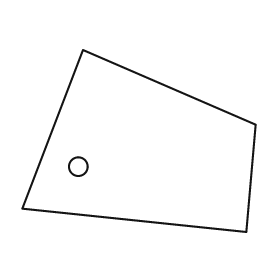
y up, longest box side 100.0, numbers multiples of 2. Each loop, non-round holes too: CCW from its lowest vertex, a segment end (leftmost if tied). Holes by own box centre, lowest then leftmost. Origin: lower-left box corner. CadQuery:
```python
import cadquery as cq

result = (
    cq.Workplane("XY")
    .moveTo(96.0, 0.0)
    .lineTo(100.0, 46.0)
    .lineTo(26.0, 78.0)
    .lineTo(0.0, 10.0)
    .close()
    .moveTo(24.0, 28.0)
    .circle(4.0)
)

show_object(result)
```